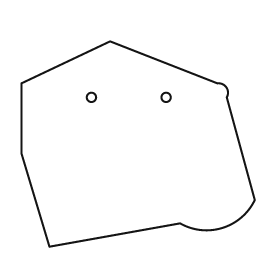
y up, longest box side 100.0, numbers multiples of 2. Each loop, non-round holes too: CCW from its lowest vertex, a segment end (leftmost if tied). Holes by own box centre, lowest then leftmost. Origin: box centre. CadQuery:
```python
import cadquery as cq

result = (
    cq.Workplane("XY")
    .moveTo(-38.0, -44.0)
    .lineTo(18.0, -34.0)
    .threePointArc((36.0, -36.0), (50.0, -24.0))
    .lineTo(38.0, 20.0)
    .threePointArc((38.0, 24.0), (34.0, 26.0))
    .lineTo(-12.0, 44.0)
    .lineTo(-50.0, 26.0)
    .lineTo(-50.0, -4.0)
    .close()
    .moveTo(-20.0, 20.0)
    .circle(2.0)
    .moveTo(12.0, 20.0)
    .circle(2.0)
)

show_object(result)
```